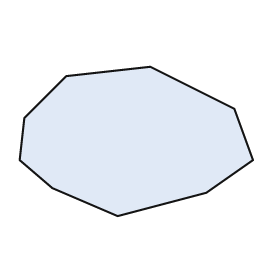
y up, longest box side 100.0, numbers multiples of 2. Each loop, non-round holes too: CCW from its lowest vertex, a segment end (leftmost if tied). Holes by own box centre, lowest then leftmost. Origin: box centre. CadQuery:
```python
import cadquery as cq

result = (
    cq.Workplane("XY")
    .moveTo(-8.0, -32.0)
    .lineTo(30.0, -22.0)
    .lineTo(50.0, -8.0)
    .lineTo(42.0, 14.0)
    .lineTo(6.0, 32.0)
    .lineTo(-30.0, 28.0)
    .lineTo(-48.0, 10.0)
    .lineTo(-50.0, -8.0)
    .lineTo(-36.0, -20.0)
    .close()
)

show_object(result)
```